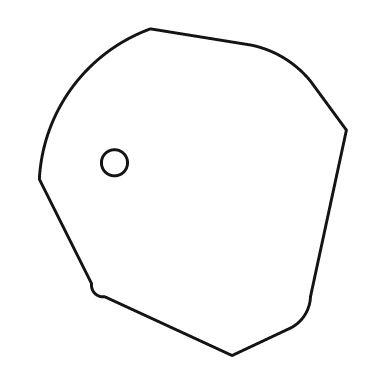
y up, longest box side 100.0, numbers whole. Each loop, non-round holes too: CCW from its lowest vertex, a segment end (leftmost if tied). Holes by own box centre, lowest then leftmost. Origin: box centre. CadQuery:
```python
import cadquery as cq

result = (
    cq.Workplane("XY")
    .moveTo(12.0, -50.0)
    .lineTo(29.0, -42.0)
    .threePointArc((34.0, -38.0), (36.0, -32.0))
    .lineTo(47.0, 19.0)
    .lineTo(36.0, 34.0)
    .threePointArc((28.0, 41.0), (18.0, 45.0))
    .lineTo(-13.0, 50.0)
    .threePointArc((-37.0, 32.0), (-47.0, 4.0))
    .lineTo(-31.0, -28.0)
    .threePointArc((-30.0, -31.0), (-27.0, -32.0))
    .close()
    .moveTo(-24.0, 9.0)
    .circle(4.0)
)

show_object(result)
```